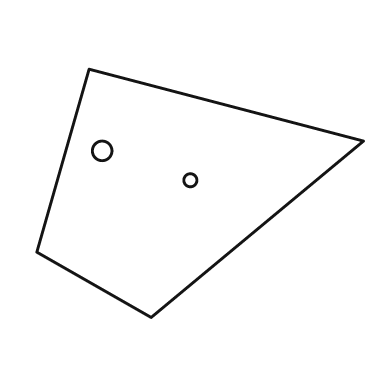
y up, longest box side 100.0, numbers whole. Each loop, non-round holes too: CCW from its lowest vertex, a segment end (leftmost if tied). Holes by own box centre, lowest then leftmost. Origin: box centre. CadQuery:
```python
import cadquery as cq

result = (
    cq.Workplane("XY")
    .moveTo(-15.0, -38.0)
    .lineTo(50.0, 16.0)
    .lineTo(-34.0, 38.0)
    .lineTo(-50.0, -18.0)
    .close()
    .moveTo(-3.0, 4.0)
    .circle(2.0)
    .moveTo(-30.0, 13.0)
    .circle(3.0)
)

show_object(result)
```